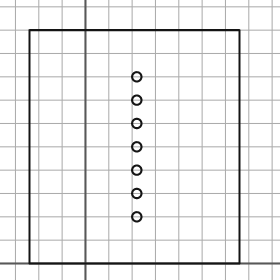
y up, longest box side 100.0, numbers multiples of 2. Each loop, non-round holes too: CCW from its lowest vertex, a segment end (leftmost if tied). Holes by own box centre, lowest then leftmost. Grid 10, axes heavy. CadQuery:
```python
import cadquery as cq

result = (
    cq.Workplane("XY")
    .moveTo(-24.0, 0.0)
    .lineTo(66.0, 0.0)
    .lineTo(66.0, 100.0)
    .lineTo(-24.0, 100.0)
    .close()
    .moveTo(22.0, 20.0)
    .circle(2.0)
    .moveTo(22.0, 30.0)
    .circle(2.0)
    .moveTo(22.0, 40.0)
    .circle(2.0)
    .moveTo(22.0, 50.0)
    .circle(2.0)
    .moveTo(22.0, 60.0)
    .circle(2.0)
    .moveTo(22.0, 70.0)
    .circle(2.0)
    .moveTo(22.0, 80.0)
    .circle(2.0)
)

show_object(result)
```